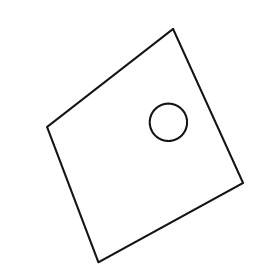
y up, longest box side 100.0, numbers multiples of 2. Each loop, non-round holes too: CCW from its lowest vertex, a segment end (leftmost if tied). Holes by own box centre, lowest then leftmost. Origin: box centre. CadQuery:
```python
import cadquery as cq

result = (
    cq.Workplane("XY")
    .moveTo(-20.0, -50.0)
    .lineTo(42.0, -16.0)
    .lineTo(12.0, 50.0)
    .lineTo(-42.0, 8.0)
    .close()
    .moveTo(10.0, 10.0)
    .circle(8.0)
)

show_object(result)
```